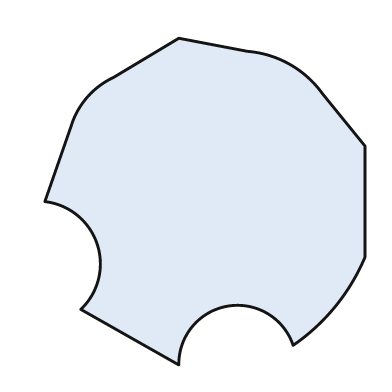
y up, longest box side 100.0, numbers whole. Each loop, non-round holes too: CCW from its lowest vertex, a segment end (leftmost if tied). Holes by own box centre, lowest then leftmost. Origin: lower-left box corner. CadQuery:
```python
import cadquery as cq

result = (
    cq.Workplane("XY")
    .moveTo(41.0, 0.0)
    .threePointArc((56.0, 18.0), (76.0, 6.0))
    .threePointArc((89.0, 18.0), (98.0, 33.0))
    .lineTo(98.0, 67.0)
    .lineTo(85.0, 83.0)
    .threePointArc((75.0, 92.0), (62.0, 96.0))
    .lineTo(41.0, 100.0)
    .lineTo(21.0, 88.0)
    .threePointArc((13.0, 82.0), (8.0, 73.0))
    .lineTo(0.0, 50.0)
    .threePointArc((16.0, 37.0), (11.0, 17.0))
    .close()
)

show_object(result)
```